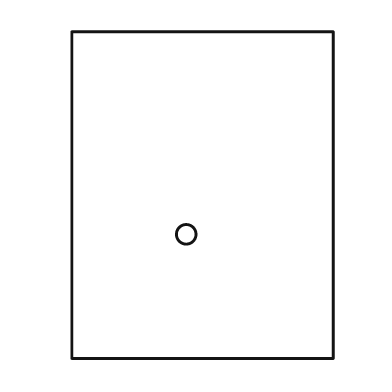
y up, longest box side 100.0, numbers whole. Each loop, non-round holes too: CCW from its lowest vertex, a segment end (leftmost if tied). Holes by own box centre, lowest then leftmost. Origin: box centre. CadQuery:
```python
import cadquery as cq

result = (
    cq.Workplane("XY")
    .moveTo(-40.0, -50.0)
    .lineTo(40.0, -50.0)
    .lineTo(40.0, 50.0)
    .lineTo(-40.0, 50.0)
    .close()
    .moveTo(-5.0, -12.0)
    .circle(3.0)
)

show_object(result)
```